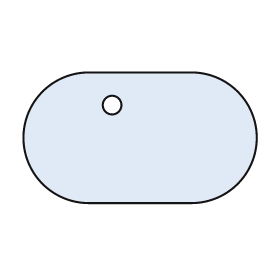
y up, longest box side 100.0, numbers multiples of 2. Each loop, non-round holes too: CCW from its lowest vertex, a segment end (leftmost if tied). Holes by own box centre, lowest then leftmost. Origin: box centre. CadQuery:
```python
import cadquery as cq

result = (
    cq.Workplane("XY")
    .moveTo(-22.0, -28.0)
    .lineTo(22.0, -28.0)
    .threePointArc((50.0, 0.0), (22.0, 28.0))
    .lineTo(-22.0, 28.0)
    .threePointArc((-50.0, 0.0), (-22.0, -28.0))
    .close()
    .moveTo(-12.0, 14.0)
    .circle(4.0)
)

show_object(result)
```